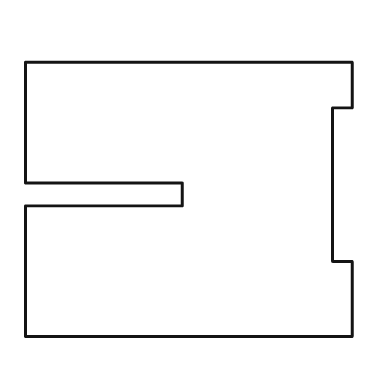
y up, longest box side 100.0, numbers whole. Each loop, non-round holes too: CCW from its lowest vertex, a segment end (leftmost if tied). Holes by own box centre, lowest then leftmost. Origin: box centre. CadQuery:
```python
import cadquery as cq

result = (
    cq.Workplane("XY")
    .moveTo(-50.0, -42.0)
    .lineTo(50.0, -42.0)
    .lineTo(50.0, -19.0)
    .lineTo(44.0, -19.0)
    .lineTo(44.0, 28.0)
    .lineTo(50.0, 28.0)
    .lineTo(50.0, 42.0)
    .lineTo(-50.0, 42.0)
    .lineTo(-50.0, 5.0)
    .lineTo(-2.0, 5.0)
    .lineTo(-2.0, -2.0)
    .lineTo(-50.0, -2.0)
    .close()
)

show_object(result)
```